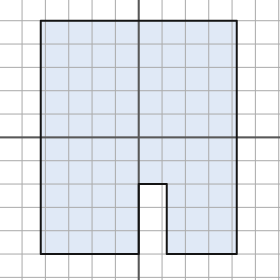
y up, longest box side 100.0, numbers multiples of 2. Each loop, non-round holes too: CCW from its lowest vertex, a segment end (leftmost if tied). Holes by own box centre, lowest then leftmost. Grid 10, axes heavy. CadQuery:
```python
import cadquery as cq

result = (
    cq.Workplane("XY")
    .moveTo(-42.0, -50.0)
    .lineTo(0.0, -50.0)
    .lineTo(0.0, -20.0)
    .lineTo(12.0, -20.0)
    .lineTo(12.0, -50.0)
    .lineTo(42.0, -50.0)
    .lineTo(42.0, 50.0)
    .lineTo(-42.0, 50.0)
    .close()
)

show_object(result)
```